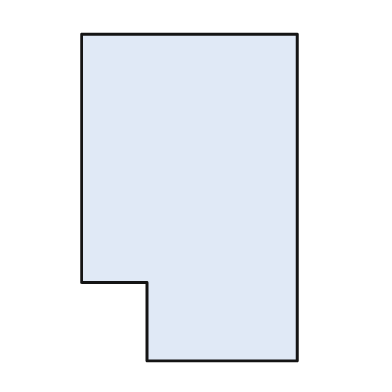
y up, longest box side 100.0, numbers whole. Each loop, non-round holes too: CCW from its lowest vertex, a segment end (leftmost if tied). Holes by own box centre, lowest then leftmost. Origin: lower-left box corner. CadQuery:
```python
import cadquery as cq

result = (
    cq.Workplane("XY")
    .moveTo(20.0, 0.0)
    .lineTo(66.0, 0.0)
    .lineTo(66.0, 100.0)
    .lineTo(0.0, 100.0)
    .lineTo(0.0, 24.0)
    .lineTo(20.0, 24.0)
    .close()
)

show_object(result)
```